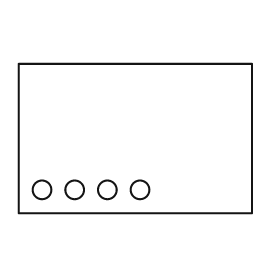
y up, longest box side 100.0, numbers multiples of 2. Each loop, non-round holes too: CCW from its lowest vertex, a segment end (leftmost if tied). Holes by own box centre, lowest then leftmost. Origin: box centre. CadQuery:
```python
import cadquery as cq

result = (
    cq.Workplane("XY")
    .moveTo(-50.0, -32.0)
    .lineTo(50.0, -32.0)
    .lineTo(50.0, 32.0)
    .lineTo(-50.0, 32.0)
    .close()
    .moveTo(-40.0, -22.0)
    .circle(4.0)
    .moveTo(-26.0, -22.0)
    .circle(4.0)
    .moveTo(-12.0, -22.0)
    .circle(4.0)
    .moveTo(2.0, -22.0)
    .circle(4.0)
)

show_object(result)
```